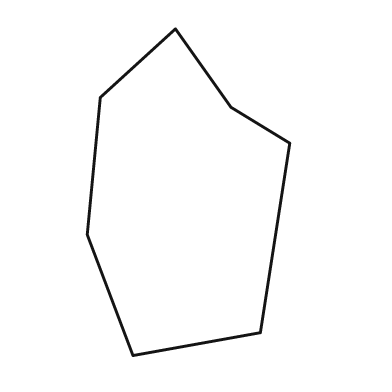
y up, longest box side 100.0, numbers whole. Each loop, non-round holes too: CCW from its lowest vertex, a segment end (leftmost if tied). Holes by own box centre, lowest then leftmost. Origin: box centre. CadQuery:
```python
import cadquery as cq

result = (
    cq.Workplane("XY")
    .moveTo(-17.0, -50.0)
    .lineTo(22.0, -43.0)
    .lineTo(31.0, 15.0)
    .lineTo(13.0, 26.0)
    .lineTo(-4.0, 50.0)
    .lineTo(-27.0, 29.0)
    .lineTo(-31.0, -13.0)
    .close()
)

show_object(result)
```